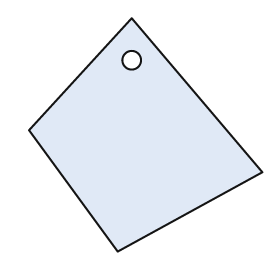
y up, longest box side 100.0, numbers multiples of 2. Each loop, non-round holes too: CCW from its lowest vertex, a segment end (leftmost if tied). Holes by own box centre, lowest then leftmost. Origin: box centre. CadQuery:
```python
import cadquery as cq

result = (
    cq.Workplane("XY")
    .moveTo(-12.0, -50.0)
    .lineTo(50.0, -16.0)
    .lineTo(-6.0, 50.0)
    .lineTo(-50.0, 2.0)
    .close()
    .moveTo(-6.0, 32.0)
    .circle(4.0)
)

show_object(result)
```